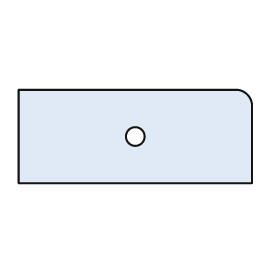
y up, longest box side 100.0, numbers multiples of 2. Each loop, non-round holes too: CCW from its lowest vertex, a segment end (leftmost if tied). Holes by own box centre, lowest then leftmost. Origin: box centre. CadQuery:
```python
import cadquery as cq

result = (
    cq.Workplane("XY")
    .moveTo(-50.0, -20.0)
    .lineTo(50.0, -20.0)
    .lineTo(50.0, 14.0)
    .threePointArc((48.0, 18.0), (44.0, 20.0))
    .lineTo(-50.0, 20.0)
    .close()
    .moveTo(0.0, 0.0)
    .circle(4.0)
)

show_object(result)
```